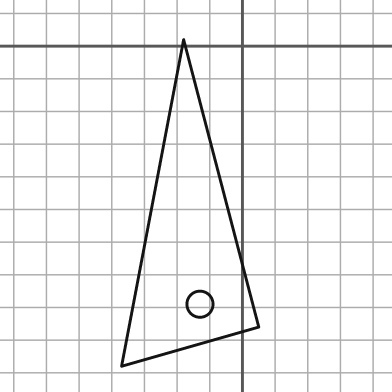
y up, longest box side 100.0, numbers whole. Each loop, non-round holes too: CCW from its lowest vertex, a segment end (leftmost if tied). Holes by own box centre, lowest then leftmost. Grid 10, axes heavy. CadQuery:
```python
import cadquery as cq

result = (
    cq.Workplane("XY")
    .moveTo(-37.0, -98.0)
    .lineTo(5.0, -86.0)
    .lineTo(-18.0, 2.0)
    .close()
    .moveTo(-13.0, -79.0)
    .circle(4.0)
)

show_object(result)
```